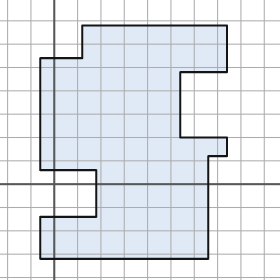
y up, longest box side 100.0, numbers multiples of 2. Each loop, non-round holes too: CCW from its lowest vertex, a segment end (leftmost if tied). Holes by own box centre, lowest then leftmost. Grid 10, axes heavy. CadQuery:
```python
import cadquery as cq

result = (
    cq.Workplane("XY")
    .moveTo(-6.0, -32.0)
    .lineTo(66.0, -32.0)
    .lineTo(66.0, 12.0)
    .lineTo(74.0, 12.0)
    .lineTo(74.0, 20.0)
    .lineTo(54.0, 20.0)
    .lineTo(54.0, 48.0)
    .lineTo(74.0, 48.0)
    .lineTo(74.0, 68.0)
    .lineTo(12.0, 68.0)
    .lineTo(12.0, 54.0)
    .lineTo(-6.0, 54.0)
    .lineTo(-6.0, 6.0)
    .lineTo(18.0, 6.0)
    .lineTo(18.0, -14.0)
    .lineTo(-6.0, -14.0)
    .close()
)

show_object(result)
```